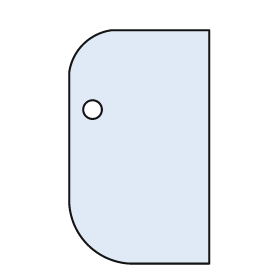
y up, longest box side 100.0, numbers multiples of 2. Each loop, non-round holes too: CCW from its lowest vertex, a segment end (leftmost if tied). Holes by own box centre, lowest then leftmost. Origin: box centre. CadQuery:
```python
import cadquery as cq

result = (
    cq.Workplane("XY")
    .moveTo(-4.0, -50.0)
    .lineTo(30.0, -50.0)
    .lineTo(30.0, 50.0)
    .lineTo(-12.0, 50.0)
    .threePointArc((-24.0, 44.0), (-30.0, 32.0))
    .lineTo(-30.0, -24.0)
    .threePointArc((-22.0, -42.0), (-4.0, -50.0))
    .close()
    .moveTo(-20.0, 16.0)
    .circle(4.0)
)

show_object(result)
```